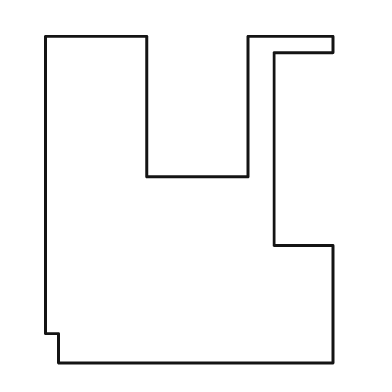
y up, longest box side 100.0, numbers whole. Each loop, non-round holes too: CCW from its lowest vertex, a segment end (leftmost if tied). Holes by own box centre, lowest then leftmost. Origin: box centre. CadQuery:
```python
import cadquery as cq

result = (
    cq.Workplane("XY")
    .moveTo(-40.0, -50.0)
    .lineTo(44.0, -50.0)
    .lineTo(44.0, -14.0)
    .lineTo(26.0, -14.0)
    .lineTo(26.0, 45.0)
    .lineTo(44.0, 45.0)
    .lineTo(44.0, 50.0)
    .lineTo(18.0, 50.0)
    .lineTo(18.0, 7.0)
    .lineTo(-13.0, 7.0)
    .lineTo(-13.0, 50.0)
    .lineTo(-44.0, 50.0)
    .lineTo(-44.0, -41.0)
    .lineTo(-40.0, -41.0)
    .close()
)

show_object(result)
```